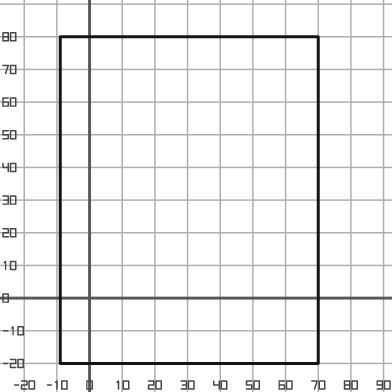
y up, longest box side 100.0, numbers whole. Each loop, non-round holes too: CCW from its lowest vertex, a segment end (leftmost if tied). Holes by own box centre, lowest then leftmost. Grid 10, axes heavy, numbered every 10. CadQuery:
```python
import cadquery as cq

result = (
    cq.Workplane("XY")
    .moveTo(-9.0, -20.0)
    .lineTo(70.0, -20.0)
    .lineTo(70.0, 80.0)
    .lineTo(-9.0, 80.0)
    .close()
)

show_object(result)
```